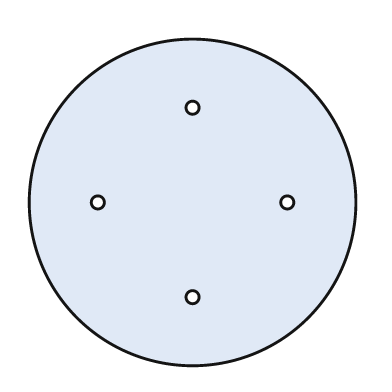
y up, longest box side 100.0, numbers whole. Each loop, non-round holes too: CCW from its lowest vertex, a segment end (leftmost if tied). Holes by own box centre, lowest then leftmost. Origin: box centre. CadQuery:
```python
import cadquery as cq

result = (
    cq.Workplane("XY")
    .moveTo(0.0, 0.0)
    .circle(50.0)
    .moveTo(0.0, -29.0)
    .circle(2.0)
    .moveTo(-29.0, 0.0)
    .circle(2.0)
    .moveTo(29.0, 0.0)
    .circle(2.0)
    .moveTo(0.0, 29.0)
    .circle(2.0)
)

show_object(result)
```